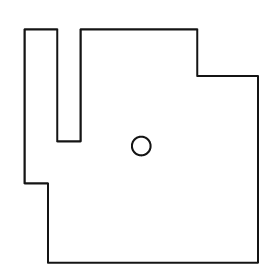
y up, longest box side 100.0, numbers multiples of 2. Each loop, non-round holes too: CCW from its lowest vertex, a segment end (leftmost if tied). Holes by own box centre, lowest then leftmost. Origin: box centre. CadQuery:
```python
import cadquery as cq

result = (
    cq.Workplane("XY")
    .moveTo(-40.0, -50.0)
    .lineTo(50.0, -50.0)
    .lineTo(50.0, 30.0)
    .lineTo(24.0, 30.0)
    .lineTo(24.0, 50.0)
    .lineTo(-26.0, 50.0)
    .lineTo(-26.0, 2.0)
    .lineTo(-36.0, 2.0)
    .lineTo(-36.0, 50.0)
    .lineTo(-50.0, 50.0)
    .lineTo(-50.0, -16.0)
    .lineTo(-40.0, -16.0)
    .close()
    .moveTo(0.0, 0.0)
    .circle(4.0)
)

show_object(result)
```